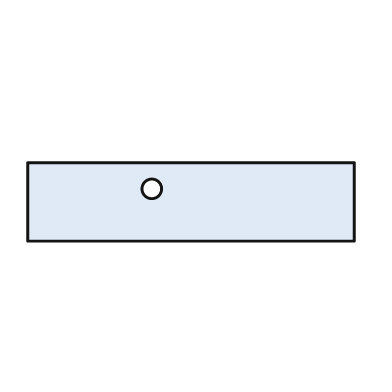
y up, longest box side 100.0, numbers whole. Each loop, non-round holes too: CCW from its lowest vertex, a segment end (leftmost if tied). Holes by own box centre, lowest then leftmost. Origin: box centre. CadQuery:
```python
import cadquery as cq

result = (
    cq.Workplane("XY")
    .moveTo(-50.0, -12.0)
    .lineTo(50.0, -12.0)
    .lineTo(50.0, 12.0)
    .lineTo(-50.0, 12.0)
    .close()
    .moveTo(-12.0, 4.0)
    .circle(3.0)
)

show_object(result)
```